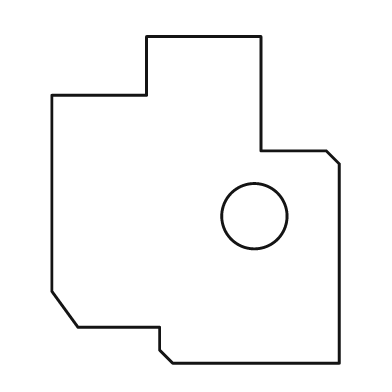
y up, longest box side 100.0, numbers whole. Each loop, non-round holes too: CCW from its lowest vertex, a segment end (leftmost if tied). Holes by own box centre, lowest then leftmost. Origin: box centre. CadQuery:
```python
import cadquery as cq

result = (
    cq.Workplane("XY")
    .moveTo(-7.0, -50.0)
    .lineTo(44.0, -50.0)
    .lineTo(44.0, 11.0)
    .lineTo(40.0, 15.0)
    .lineTo(20.0, 15.0)
    .lineTo(20.0, 50.0)
    .lineTo(-15.0, 50.0)
    .lineTo(-15.0, 32.0)
    .lineTo(-44.0, 32.0)
    .lineTo(-44.0, -28.0)
    .lineTo(-36.0, -39.0)
    .lineTo(-11.0, -39.0)
    .lineTo(-11.0, -46.0)
    .close()
    .moveTo(18.0, -5.0)
    .circle(10.0)
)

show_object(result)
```